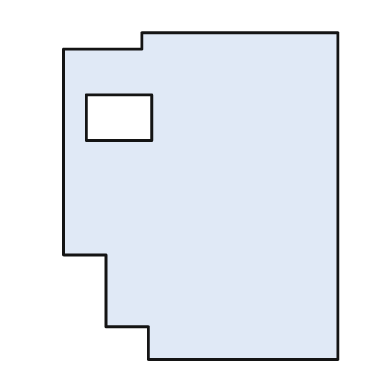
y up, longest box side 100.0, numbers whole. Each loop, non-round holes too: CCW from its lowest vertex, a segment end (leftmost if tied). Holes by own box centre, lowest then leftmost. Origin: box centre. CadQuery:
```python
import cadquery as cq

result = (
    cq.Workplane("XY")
    .moveTo(-16.0, -50.0)
    .lineTo(42.0, -50.0)
    .lineTo(42.0, 50.0)
    .lineTo(-18.0, 50.0)
    .lineTo(-18.0, 45.0)
    .lineTo(-42.0, 45.0)
    .lineTo(-42.0, -18.0)
    .lineTo(-29.0, -18.0)
    .lineTo(-29.0, -40.0)
    .lineTo(-16.0, -40.0)
    .close()
    .moveTo(-35.0, 17.0)
    .lineTo(-15.0, 17.0)
    .lineTo(-15.0, 31.0)
    .lineTo(-35.0, 31.0)
    .close()
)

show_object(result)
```